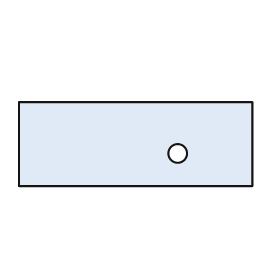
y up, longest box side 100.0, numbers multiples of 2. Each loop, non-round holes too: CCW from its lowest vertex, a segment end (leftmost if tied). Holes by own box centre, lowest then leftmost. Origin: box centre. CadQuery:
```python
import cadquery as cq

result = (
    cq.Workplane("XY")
    .moveTo(-50.0, -18.0)
    .lineTo(50.0, -18.0)
    .lineTo(50.0, 18.0)
    .lineTo(-50.0, 18.0)
    .close()
    .moveTo(18.0, -4.0)
    .circle(4.0)
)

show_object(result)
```